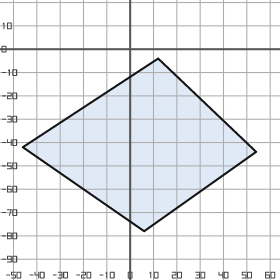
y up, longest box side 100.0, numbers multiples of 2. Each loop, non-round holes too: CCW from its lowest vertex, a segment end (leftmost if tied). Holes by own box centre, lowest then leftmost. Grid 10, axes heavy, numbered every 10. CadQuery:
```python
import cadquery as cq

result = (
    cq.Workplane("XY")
    .moveTo(6.0, -78.0)
    .lineTo(54.0, -44.0)
    .lineTo(12.0, -4.0)
    .lineTo(-46.0, -42.0)
    .close()
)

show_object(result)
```